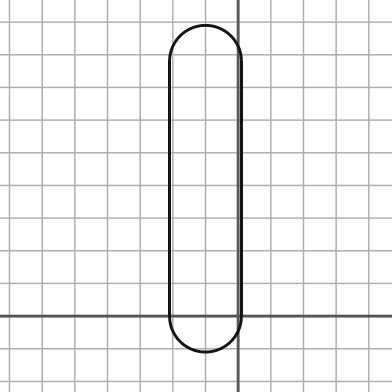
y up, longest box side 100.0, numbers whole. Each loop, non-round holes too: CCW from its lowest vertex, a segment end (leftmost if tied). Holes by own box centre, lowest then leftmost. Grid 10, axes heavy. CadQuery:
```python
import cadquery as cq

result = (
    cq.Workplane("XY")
    .moveTo(-21.0, 0.0)
    .threePointArc((-10.0, -11.0), (1.0, 0.0))
    .lineTo(1.0, 78.0)
    .threePointArc((-10.0, 89.0), (-21.0, 78.0))
    .close()
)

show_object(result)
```